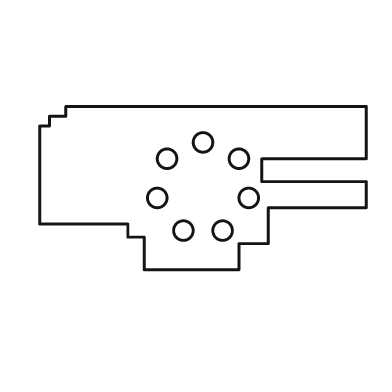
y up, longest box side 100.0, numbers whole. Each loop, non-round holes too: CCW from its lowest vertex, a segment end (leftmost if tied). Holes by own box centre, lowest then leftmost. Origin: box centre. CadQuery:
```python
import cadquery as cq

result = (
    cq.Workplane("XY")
    .moveTo(-18.0, -25.0)
    .lineTo(11.0, -25.0)
    .lineTo(11.0, -17.0)
    .lineTo(20.0, -17.0)
    .lineTo(20.0, -6.0)
    .lineTo(50.0, -6.0)
    .lineTo(50.0, 2.0)
    .lineTo(18.0, 2.0)
    .lineTo(18.0, 9.0)
    .lineTo(50.0, 9.0)
    .lineTo(50.0, 25.0)
    .lineTo(-42.0, 25.0)
    .lineTo(-42.0, 22.0)
    .lineTo(-47.0, 22.0)
    .lineTo(-47.0, 19.0)
    .lineTo(-50.0, 19.0)
    .lineTo(-50.0, -11.0)
    .lineTo(-23.0, -11.0)
    .lineTo(-23.0, -15.0)
    .lineTo(-18.0, -15.0)
    .close()
    .moveTo(-6.0, -13.0)
    .circle(3.0)
    .moveTo(6.0, -13.0)
    .circle(3.0)
    .moveTo(-14.0, -3.0)
    .circle(3.0)
    .moveTo(14.0, -3.0)
    .circle(3.0)
    .moveTo(-11.0, 9.0)
    .circle(3.0)
    .moveTo(11.0, 9.0)
    .circle(3.0)
    .moveTo(0.0, 14.0)
    .circle(3.0)
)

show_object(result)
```